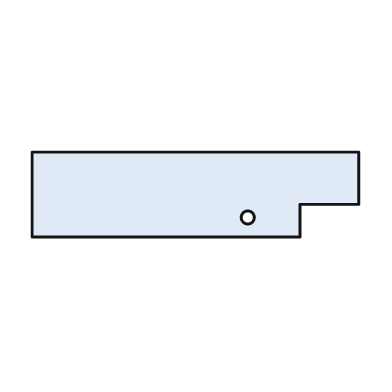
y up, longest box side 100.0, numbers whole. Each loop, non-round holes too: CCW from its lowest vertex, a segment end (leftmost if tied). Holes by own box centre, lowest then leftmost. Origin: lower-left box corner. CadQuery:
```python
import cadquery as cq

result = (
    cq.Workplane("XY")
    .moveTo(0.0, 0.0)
    .lineTo(82.0, 0.0)
    .lineTo(82.0, 10.0)
    .lineTo(100.0, 10.0)
    .lineTo(100.0, 26.0)
    .lineTo(0.0, 26.0)
    .close()
    .moveTo(66.0, 6.0)
    .circle(2.0)
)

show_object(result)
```